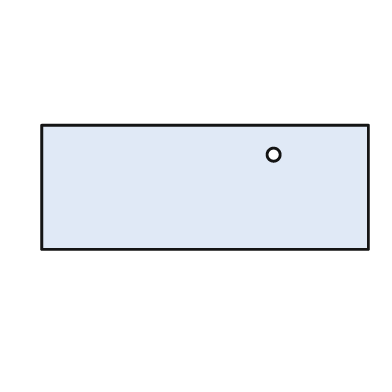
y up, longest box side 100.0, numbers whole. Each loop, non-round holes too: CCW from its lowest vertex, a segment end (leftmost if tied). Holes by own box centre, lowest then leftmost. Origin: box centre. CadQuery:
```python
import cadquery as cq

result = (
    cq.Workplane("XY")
    .moveTo(-50.0, -19.0)
    .lineTo(50.0, -19.0)
    .lineTo(50.0, 19.0)
    .lineTo(-50.0, 19.0)
    .close()
    .moveTo(21.0, 10.0)
    .circle(2.0)
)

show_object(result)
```